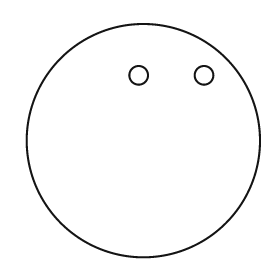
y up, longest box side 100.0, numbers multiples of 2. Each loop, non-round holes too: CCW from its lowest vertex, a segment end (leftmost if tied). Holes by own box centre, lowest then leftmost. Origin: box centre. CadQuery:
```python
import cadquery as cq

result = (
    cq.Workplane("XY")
    .moveTo(0.0, 0.0)
    .circle(50.0)
    .moveTo(-2.0, 28.0)
    .circle(4.0)
    .moveTo(26.0, 28.0)
    .circle(4.0)
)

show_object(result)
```